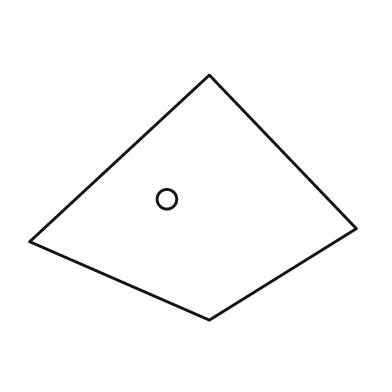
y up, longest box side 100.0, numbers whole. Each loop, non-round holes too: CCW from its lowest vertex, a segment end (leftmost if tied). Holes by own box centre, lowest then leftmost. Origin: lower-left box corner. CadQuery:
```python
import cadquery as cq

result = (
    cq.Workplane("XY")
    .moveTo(55.0, 0.0)
    .lineTo(100.0, 28.0)
    .lineTo(55.0, 75.0)
    .lineTo(0.0, 24.0)
    .close()
    .moveTo(42.0, 37.0)
    .circle(3.0)
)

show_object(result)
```